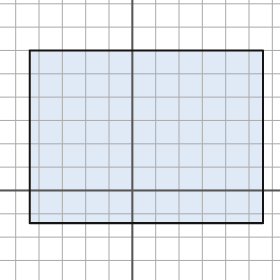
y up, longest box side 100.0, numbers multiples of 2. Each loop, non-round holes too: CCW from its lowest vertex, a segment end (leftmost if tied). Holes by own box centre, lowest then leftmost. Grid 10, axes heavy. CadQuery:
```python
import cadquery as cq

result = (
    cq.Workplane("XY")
    .moveTo(-44.0, -14.0)
    .lineTo(56.0, -14.0)
    .lineTo(56.0, 60.0)
    .lineTo(-44.0, 60.0)
    .close()
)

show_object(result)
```